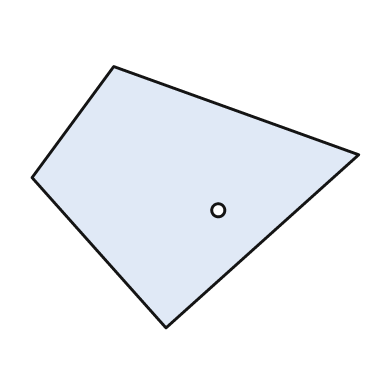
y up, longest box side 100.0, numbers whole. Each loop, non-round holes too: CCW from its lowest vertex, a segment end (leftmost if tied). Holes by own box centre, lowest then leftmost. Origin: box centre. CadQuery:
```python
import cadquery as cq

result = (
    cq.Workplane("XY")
    .moveTo(-9.0, -40.0)
    .lineTo(50.0, 13.0)
    .lineTo(-25.0, 40.0)
    .lineTo(-50.0, 6.0)
    .close()
    .moveTo(7.0, -4.0)
    .circle(2.0)
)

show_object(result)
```